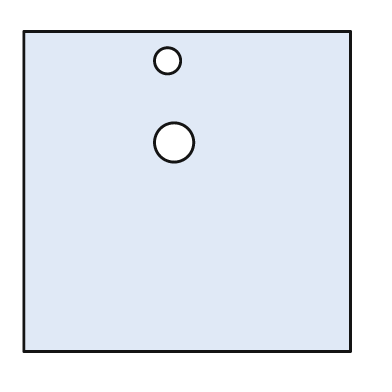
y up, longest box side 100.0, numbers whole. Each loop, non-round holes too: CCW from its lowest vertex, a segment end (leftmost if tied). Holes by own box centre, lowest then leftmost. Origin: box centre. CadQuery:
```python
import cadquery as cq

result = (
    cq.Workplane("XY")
    .moveTo(-50.0, -49.0)
    .lineTo(50.0, -49.0)
    .lineTo(50.0, 49.0)
    .lineTo(-50.0, 49.0)
    .close()
    .moveTo(-4.0, 15.0)
    .circle(6.0)
    .moveTo(-6.0, 40.0)
    .circle(4.0)
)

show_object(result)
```